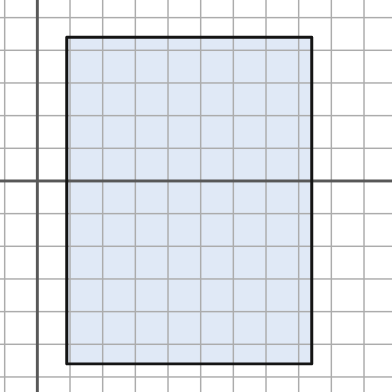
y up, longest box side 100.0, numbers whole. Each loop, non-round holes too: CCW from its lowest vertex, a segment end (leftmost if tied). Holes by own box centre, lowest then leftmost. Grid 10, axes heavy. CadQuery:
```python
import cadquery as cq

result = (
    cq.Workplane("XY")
    .moveTo(9.0, -56.0)
    .lineTo(84.0, -56.0)
    .lineTo(84.0, 44.0)
    .lineTo(9.0, 44.0)
    .close()
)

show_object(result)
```